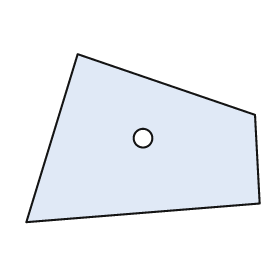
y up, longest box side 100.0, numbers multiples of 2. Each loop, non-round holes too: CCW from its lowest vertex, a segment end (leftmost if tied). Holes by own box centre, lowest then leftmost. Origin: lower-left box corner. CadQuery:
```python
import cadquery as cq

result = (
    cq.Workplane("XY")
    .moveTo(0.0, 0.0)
    .lineTo(100.0, 8.0)
    .lineTo(98.0, 46.0)
    .lineTo(22.0, 72.0)
    .close()
    .moveTo(50.0, 36.0)
    .circle(4.0)
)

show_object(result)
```